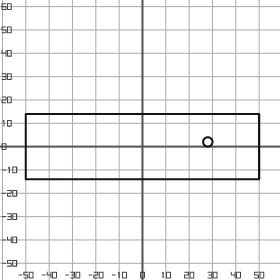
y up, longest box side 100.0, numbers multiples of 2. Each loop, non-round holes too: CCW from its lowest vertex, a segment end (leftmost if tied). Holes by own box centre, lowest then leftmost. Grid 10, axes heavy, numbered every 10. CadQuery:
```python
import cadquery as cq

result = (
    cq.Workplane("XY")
    .moveTo(-50.0, -14.0)
    .lineTo(50.0, -14.0)
    .lineTo(50.0, 14.0)
    .lineTo(-50.0, 14.0)
    .close()
    .moveTo(28.0, 2.0)
    .circle(2.0)
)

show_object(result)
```